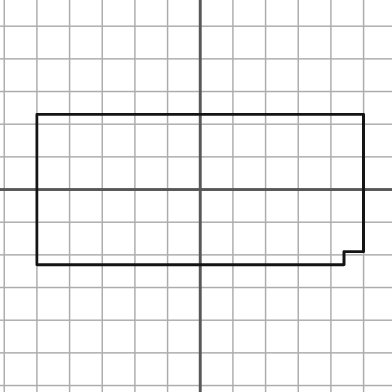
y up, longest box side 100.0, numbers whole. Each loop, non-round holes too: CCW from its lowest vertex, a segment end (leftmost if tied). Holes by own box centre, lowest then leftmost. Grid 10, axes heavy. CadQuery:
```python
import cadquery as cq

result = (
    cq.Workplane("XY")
    .moveTo(-50.0, -23.0)
    .lineTo(44.0, -23.0)
    .lineTo(44.0, -19.0)
    .lineTo(50.0, -19.0)
    .lineTo(50.0, 23.0)
    .lineTo(-50.0, 23.0)
    .close()
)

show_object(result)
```